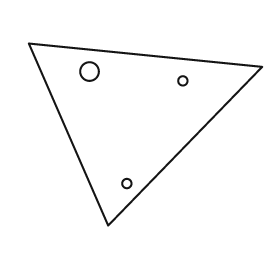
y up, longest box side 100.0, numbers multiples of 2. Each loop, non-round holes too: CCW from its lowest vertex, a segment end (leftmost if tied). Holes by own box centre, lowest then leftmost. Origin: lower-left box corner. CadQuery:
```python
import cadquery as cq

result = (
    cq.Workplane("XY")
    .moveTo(34.0, 0.0)
    .lineTo(100.0, 68.0)
    .lineTo(0.0, 78.0)
    .close()
    .moveTo(42.0, 18.0)
    .circle(2.0)
    .moveTo(66.0, 62.0)
    .circle(2.0)
    .moveTo(26.0, 66.0)
    .circle(4.0)
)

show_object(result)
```